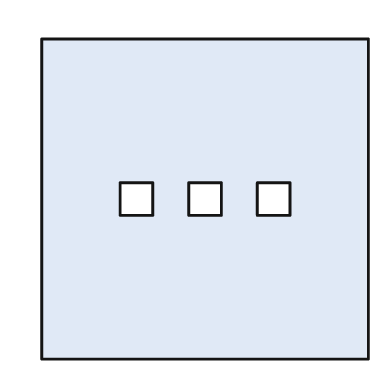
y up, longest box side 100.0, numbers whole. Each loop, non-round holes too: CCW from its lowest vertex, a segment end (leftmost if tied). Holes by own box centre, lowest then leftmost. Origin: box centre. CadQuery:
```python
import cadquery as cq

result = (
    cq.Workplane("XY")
    .moveTo(-50.0, -49.0)
    .lineTo(50.0, -49.0)
    .lineTo(50.0, 49.0)
    .lineTo(-50.0, 49.0)
    .close()
    .moveTo(-26.0, -5.0)
    .lineTo(-16.0, -5.0)
    .lineTo(-16.0, 5.0)
    .lineTo(-26.0, 5.0)
    .close()
    .moveTo(-5.0, -5.0)
    .lineTo(5.0, -5.0)
    .lineTo(5.0, 5.0)
    .lineTo(-5.0, 5.0)
    .close()
    .moveTo(16.0, -5.0)
    .lineTo(26.0, -5.0)
    .lineTo(26.0, 5.0)
    .lineTo(16.0, 5.0)
    .close()
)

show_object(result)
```